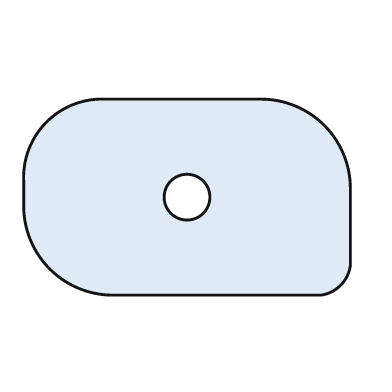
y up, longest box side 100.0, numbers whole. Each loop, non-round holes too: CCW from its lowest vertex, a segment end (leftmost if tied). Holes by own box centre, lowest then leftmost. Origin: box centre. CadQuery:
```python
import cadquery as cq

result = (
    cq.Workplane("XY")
    .moveTo(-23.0, -30.0)
    .lineTo(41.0, -30.0)
    .threePointArc((47.0, -27.0), (50.0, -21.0))
    .lineTo(50.0, 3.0)
    .threePointArc((42.0, 22.0), (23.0, 30.0))
    .lineTo(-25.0, 30.0)
    .threePointArc((-43.0, 23.0), (-50.0, 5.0))
    .lineTo(-50.0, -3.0)
    .threePointArc((-42.0, -22.0), (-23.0, -30.0))
    .close()
    .moveTo(0.0, 0.0)
    .circle(7.0)
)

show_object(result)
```